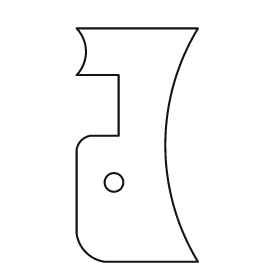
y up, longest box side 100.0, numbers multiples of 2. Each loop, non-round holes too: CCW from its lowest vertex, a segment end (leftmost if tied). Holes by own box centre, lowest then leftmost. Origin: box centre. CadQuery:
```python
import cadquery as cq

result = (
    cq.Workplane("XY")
    .moveTo(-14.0, -50.0)
    .lineTo(26.0, -50.0)
    .threePointArc((12.0, 0.0), (26.0, 50.0))
    .lineTo(-26.0, 50.0)
    .threePointArc((-22.0, 40.0), (-26.0, 30.0))
    .lineTo(-8.0, 30.0)
    .lineTo(-8.0, 4.0)
    .lineTo(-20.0, 4.0)
    .threePointArc((-24.0, 2.0), (-26.0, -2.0))
    .lineTo(-26.0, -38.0)
    .threePointArc((-22.0, -46.0), (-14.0, -50.0))
    .close()
    .moveTo(-10.0, -16.0)
    .circle(4.0)
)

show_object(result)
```